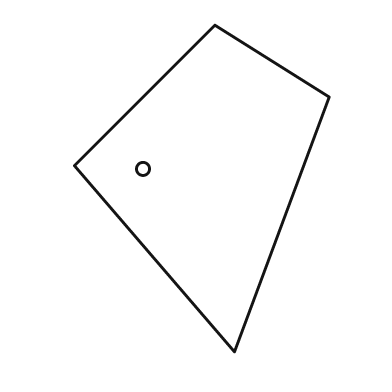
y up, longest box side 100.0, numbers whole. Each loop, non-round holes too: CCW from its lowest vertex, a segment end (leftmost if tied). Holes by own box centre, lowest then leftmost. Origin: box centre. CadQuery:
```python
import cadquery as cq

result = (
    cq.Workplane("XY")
    .moveTo(10.0, -50.0)
    .lineTo(39.0, 28.0)
    .lineTo(4.0, 50.0)
    .lineTo(-39.0, 7.0)
    .close()
    .moveTo(-18.0, 6.0)
    .circle(2.0)
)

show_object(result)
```